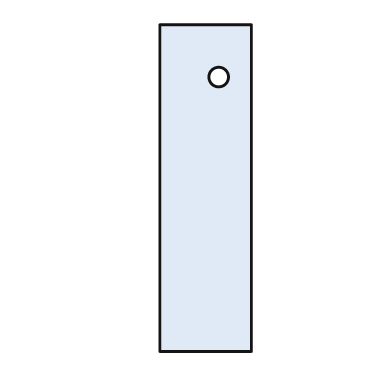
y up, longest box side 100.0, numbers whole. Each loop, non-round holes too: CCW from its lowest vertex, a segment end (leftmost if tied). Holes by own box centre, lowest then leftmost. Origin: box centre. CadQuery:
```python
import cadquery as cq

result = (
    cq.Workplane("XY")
    .moveTo(-14.0, -50.0)
    .lineTo(14.0, -50.0)
    .lineTo(14.0, 50.0)
    .lineTo(-14.0, 50.0)
    .close()
    .moveTo(4.0, 34.0)
    .circle(3.0)
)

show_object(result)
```